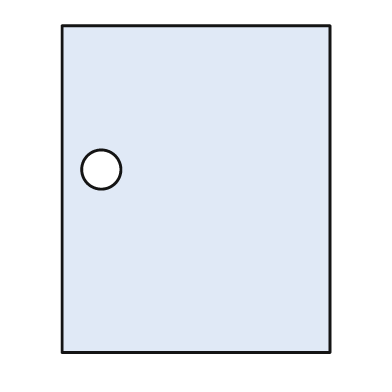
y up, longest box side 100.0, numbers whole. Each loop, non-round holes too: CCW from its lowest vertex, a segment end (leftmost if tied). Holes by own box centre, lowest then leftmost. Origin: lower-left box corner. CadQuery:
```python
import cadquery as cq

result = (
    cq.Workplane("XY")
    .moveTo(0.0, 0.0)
    .lineTo(82.0, 0.0)
    .lineTo(82.0, 100.0)
    .lineTo(0.0, 100.0)
    .close()
    .moveTo(12.0, 56.0)
    .circle(6.0)
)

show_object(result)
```